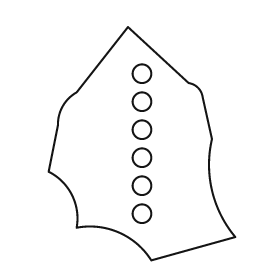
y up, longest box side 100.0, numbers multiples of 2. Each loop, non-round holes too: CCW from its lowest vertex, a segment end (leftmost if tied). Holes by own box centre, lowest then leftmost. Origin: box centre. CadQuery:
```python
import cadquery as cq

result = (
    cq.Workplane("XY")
    .moveTo(4.0, -50.0)
    .lineTo(40.0, -40.0)
    .threePointArc((30.0, -20.0), (30.0, 2.0))
    .lineTo(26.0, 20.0)
    .threePointArc((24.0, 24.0), (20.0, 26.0))
    .lineTo(-6.0, 50.0)
    .lineTo(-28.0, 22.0)
    .threePointArc((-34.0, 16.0), (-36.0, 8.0))
    .lineTo(-40.0, -12.0)
    .threePointArc((-30.0, -22.0), (-28.0, -36.0))
    .threePointArc((-10.0, -38.0), (4.0, -50.0))
    .close()
    .moveTo(0.0, -30.0)
    .circle(4.0)
    .moveTo(0.0, -18.0)
    .circle(4.0)
    .moveTo(0.0, -6.0)
    .circle(4.0)
    .moveTo(0.0, 6.0)
    .circle(4.0)
    .moveTo(0.0, 18.0)
    .circle(4.0)
    .moveTo(0.0, 30.0)
    .circle(4.0)
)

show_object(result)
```